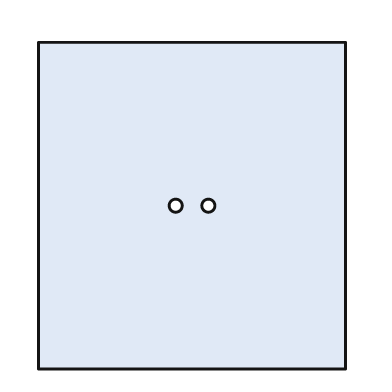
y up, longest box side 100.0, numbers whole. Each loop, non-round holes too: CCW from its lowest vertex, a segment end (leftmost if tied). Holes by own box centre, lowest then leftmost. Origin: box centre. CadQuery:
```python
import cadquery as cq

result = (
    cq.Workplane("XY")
    .moveTo(-47.0, -50.0)
    .lineTo(47.0, -50.0)
    .lineTo(47.0, 50.0)
    .lineTo(-47.0, 50.0)
    .close()
    .moveTo(-5.0, 0.0)
    .circle(2.0)
    .moveTo(5.0, 0.0)
    .circle(2.0)
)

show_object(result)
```